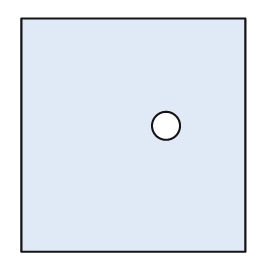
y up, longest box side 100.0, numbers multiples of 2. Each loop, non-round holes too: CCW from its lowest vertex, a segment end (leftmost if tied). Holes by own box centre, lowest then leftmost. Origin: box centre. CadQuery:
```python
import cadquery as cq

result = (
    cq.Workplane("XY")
    .moveTo(-48.0, -50.0)
    .lineTo(48.0, -50.0)
    .lineTo(48.0, 50.0)
    .lineTo(-48.0, 50.0)
    .close()
    .moveTo(14.0, 4.0)
    .circle(6.0)
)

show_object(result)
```